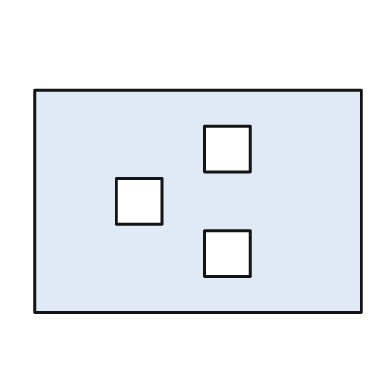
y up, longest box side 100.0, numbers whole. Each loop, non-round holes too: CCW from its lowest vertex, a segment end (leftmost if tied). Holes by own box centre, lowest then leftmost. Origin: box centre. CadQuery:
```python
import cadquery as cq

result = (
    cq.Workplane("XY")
    .moveTo(-50.0, -34.0)
    .lineTo(50.0, -34.0)
    .lineTo(50.0, 34.0)
    .lineTo(-50.0, 34.0)
    .close()
    .moveTo(2.0, -23.0)
    .lineTo(16.0, -23.0)
    .lineTo(16.0, -9.0)
    .lineTo(2.0, -9.0)
    .close()
    .moveTo(-25.0, -7.0)
    .lineTo(-11.0, -7.0)
    .lineTo(-11.0, 7.0)
    .lineTo(-25.0, 7.0)
    .close()
    .moveTo(2.0, 9.0)
    .lineTo(16.0, 9.0)
    .lineTo(16.0, 23.0)
    .lineTo(2.0, 23.0)
    .close()
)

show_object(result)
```